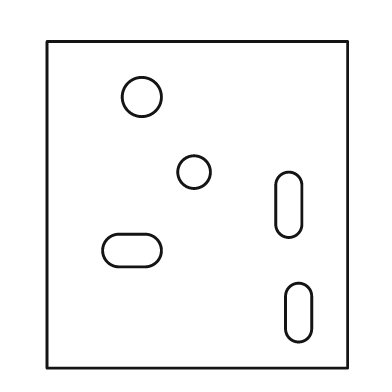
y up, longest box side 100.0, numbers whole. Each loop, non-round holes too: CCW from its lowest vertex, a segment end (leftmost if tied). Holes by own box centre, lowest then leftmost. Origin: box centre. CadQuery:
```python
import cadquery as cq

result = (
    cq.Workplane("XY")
    .moveTo(-46.0, -50.0)
    .lineTo(46.0, -50.0)
    .lineTo(46.0, 50.0)
    .lineTo(-46.0, 50.0)
    .close()
    .moveTo(27.0, -38.0)
    .threePointArc((31.0, -42.0), (35.0, -38.0))
    .lineTo(35.0, -28.0)
    .threePointArc((31.0, -24.0), (27.0, -28.0))
    .close()
    .moveTo(-24.0, -19.0)
    .lineTo(-16.0, -19.0)
    .threePointArc((-11.0, -14.0), (-16.0, -9.0))
    .lineTo(-24.0, -9.0)
    .threePointArc((-29.0, -14.0), (-24.0, -19.0))
    .close()
    .moveTo(24.0, -6.0)
    .threePointArc((28.0, -10.0), (32.0, -6.0))
    .lineTo(32.0, 6.0)
    .threePointArc((28.0, 10.0), (24.0, 6.0))
    .close()
    .moveTo(-1.0, 10.0)
    .circle(5.0)
    .moveTo(-17.0, 33.0)
    .circle(6.0)
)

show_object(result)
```